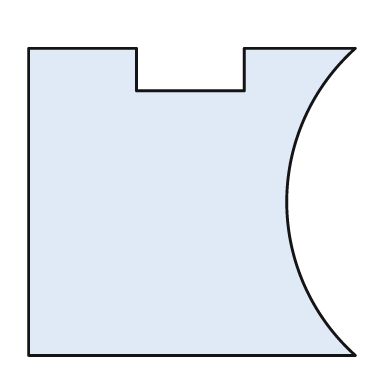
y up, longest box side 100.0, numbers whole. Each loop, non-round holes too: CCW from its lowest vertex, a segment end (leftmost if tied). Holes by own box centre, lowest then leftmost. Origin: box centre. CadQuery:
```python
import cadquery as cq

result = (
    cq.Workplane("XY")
    .moveTo(-50.0, -47.0)
    .lineTo(50.0, -47.0)
    .threePointArc((29.0, 0.0), (50.0, 47.0))
    .lineTo(16.0, 47.0)
    .lineTo(16.0, 34.0)
    .lineTo(-17.0, 34.0)
    .lineTo(-17.0, 47.0)
    .lineTo(-50.0, 47.0)
    .close()
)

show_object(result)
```